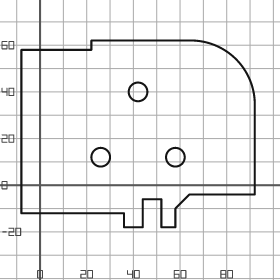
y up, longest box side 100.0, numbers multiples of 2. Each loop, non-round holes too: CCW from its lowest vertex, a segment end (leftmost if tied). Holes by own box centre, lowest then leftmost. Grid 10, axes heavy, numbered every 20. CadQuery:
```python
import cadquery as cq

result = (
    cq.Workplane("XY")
    .moveTo(36.0, -18.0)
    .lineTo(44.0, -18.0)
    .lineTo(44.0, -6.0)
    .lineTo(52.0, -6.0)
    .lineTo(52.0, -18.0)
    .lineTo(58.0, -18.0)
    .lineTo(58.0, -10.0)
    .lineTo(64.0, -4.0)
    .lineTo(92.0, -4.0)
    .lineTo(92.0, 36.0)
    .threePointArc((84.0, 54.0), (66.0, 62.0))
    .lineTo(22.0, 62.0)
    .lineTo(22.0, 58.0)
    .lineTo(-8.0, 58.0)
    .lineTo(-8.0, -12.0)
    .lineTo(36.0, -12.0)
    .close()
    .moveTo(26.0, 12.0)
    .circle(4.0)
    .moveTo(58.0, 12.0)
    .circle(4.0)
    .moveTo(42.0, 40.0)
    .circle(4.0)
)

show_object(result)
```